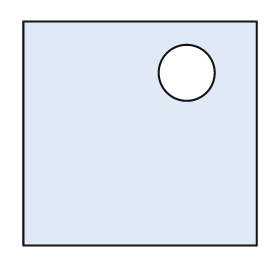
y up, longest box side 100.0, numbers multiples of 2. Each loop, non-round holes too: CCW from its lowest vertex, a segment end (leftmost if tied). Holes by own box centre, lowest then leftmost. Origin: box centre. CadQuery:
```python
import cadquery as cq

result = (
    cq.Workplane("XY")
    .moveTo(-50.0, -48.0)
    .lineTo(50.0, -48.0)
    .lineTo(50.0, 48.0)
    .lineTo(-50.0, 48.0)
    .close()
    .moveTo(20.0, 26.0)
    .circle(12.0)
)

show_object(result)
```